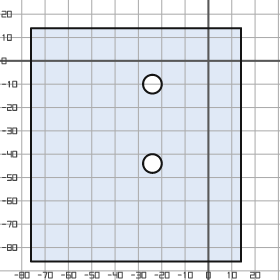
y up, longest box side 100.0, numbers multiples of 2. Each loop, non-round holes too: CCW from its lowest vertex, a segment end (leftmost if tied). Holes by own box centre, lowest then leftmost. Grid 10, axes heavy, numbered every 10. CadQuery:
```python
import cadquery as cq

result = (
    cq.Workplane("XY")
    .moveTo(-76.0, -86.0)
    .lineTo(14.0, -86.0)
    .lineTo(14.0, 14.0)
    .lineTo(-76.0, 14.0)
    .close()
    .moveTo(-24.0, -44.0)
    .circle(4.0)
    .moveTo(-24.0, -10.0)
    .circle(4.0)
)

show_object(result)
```